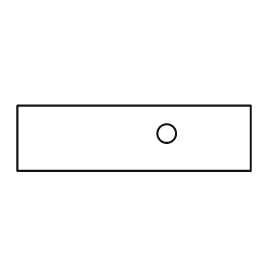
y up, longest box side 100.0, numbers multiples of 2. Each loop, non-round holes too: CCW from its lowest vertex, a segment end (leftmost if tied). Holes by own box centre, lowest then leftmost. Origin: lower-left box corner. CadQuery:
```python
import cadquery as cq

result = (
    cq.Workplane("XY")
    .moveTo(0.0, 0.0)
    .lineTo(100.0, 0.0)
    .lineTo(100.0, 28.0)
    .lineTo(0.0, 28.0)
    .close()
    .moveTo(64.0, 16.0)
    .circle(4.0)
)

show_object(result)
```